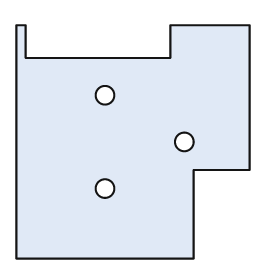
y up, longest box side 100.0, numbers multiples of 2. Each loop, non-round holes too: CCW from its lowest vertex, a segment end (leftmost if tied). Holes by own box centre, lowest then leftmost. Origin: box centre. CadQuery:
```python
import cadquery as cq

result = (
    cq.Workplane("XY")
    .moveTo(-50.0, -50.0)
    .lineTo(26.0, -50.0)
    .lineTo(26.0, -12.0)
    .lineTo(50.0, -12.0)
    .lineTo(50.0, 50.0)
    .lineTo(16.0, 50.0)
    .lineTo(16.0, 36.0)
    .lineTo(-46.0, 36.0)
    .lineTo(-46.0, 50.0)
    .lineTo(-50.0, 50.0)
    .close()
    .moveTo(-12.0, -20.0)
    .circle(4.0)
    .moveTo(22.0, 0.0)
    .circle(4.0)
    .moveTo(-12.0, 20.0)
    .circle(4.0)
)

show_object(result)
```